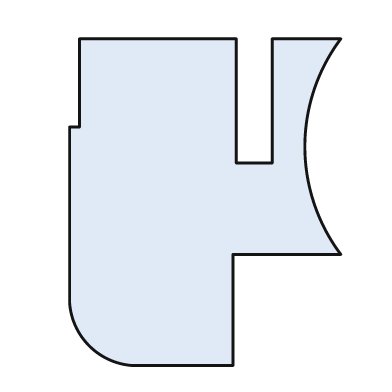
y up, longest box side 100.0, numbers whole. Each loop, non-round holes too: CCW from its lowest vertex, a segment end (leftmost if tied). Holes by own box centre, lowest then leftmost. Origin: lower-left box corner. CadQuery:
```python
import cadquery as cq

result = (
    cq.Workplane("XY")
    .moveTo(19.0, 0.0)
    .lineTo(50.0, 0.0)
    .lineTo(50.0, 34.0)
    .lineTo(83.0, 34.0)
    .threePointArc((72.0, 67.0), (83.0, 100.0))
    .lineTo(62.0, 100.0)
    .lineTo(62.0, 62.0)
    .lineTo(51.0, 62.0)
    .lineTo(51.0, 100.0)
    .lineTo(3.0, 100.0)
    .lineTo(3.0, 73.0)
    .lineTo(0.0, 73.0)
    .lineTo(0.0, 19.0)
    .threePointArc((6.0, 6.0), (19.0, 0.0))
    .close()
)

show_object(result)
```